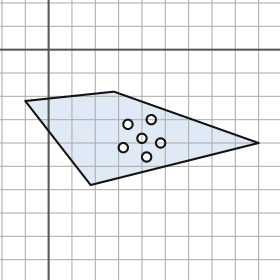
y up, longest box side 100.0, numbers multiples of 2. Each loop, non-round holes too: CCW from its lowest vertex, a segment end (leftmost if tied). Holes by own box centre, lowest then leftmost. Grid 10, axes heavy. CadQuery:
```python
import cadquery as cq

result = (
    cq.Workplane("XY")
    .moveTo(18.0, -58.0)
    .lineTo(90.0, -40.0)
    .lineTo(28.0, -18.0)
    .lineTo(-10.0, -22.0)
    .close()
    .moveTo(42.0, -46.0)
    .circle(2.0)
    .moveTo(32.0, -42.0)
    .circle(2.0)
    .moveTo(48.0, -40.0)
    .circle(2.0)
    .moveTo(40.0, -38.0)
    .circle(2.0)
    .moveTo(34.0, -32.0)
    .circle(2.0)
    .moveTo(44.0, -30.0)
    .circle(2.0)
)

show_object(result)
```